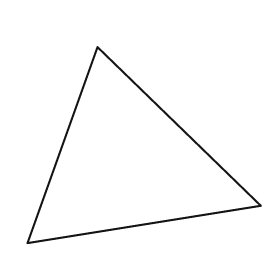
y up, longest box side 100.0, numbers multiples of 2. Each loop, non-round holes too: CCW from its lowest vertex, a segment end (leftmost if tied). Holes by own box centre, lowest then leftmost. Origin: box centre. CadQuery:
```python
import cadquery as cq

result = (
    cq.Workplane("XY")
    .moveTo(-50.0, -42.0)
    .lineTo(50.0, -26.0)
    .lineTo(-20.0, 42.0)
    .close()
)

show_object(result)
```